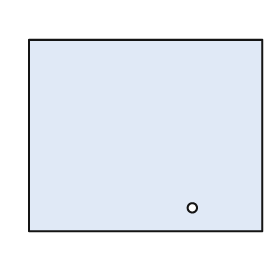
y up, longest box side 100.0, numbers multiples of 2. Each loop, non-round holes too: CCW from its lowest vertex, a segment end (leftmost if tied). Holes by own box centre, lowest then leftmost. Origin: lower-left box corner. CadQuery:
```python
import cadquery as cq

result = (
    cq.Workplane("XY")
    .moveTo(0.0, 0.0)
    .lineTo(100.0, 0.0)
    .lineTo(100.0, 82.0)
    .lineTo(0.0, 82.0)
    .close()
    .moveTo(70.0, 10.0)
    .circle(2.0)
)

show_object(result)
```